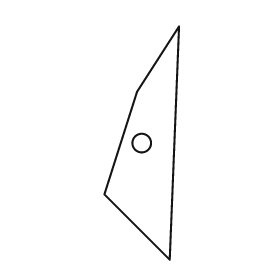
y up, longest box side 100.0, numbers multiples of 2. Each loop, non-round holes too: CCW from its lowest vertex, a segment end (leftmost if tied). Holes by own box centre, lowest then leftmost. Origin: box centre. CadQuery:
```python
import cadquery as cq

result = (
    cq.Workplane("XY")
    .moveTo(12.0, -50.0)
    .lineTo(16.0, 50.0)
    .lineTo(-2.0, 22.0)
    .lineTo(-16.0, -22.0)
    .close()
    .moveTo(0.0, 0.0)
    .circle(4.0)
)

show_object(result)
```